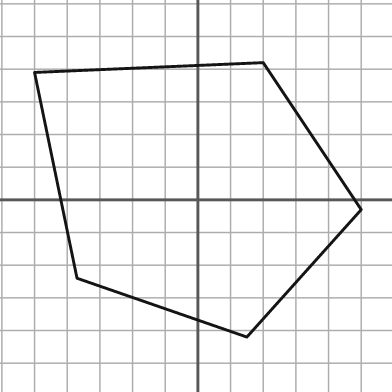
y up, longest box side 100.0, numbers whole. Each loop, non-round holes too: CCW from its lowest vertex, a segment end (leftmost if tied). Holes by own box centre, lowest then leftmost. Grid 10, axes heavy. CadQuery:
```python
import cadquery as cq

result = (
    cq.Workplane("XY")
    .moveTo(15.0, -42.0)
    .lineTo(50.0, -3.0)
    .lineTo(20.0, 42.0)
    .lineTo(-50.0, 39.0)
    .lineTo(-37.0, -24.0)
    .close()
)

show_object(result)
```